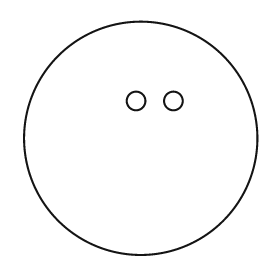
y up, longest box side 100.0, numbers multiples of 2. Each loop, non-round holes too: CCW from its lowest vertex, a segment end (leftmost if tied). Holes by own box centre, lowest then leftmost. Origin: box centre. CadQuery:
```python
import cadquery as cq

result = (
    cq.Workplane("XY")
    .moveTo(0.0, 0.0)
    .circle(50.0)
    .moveTo(-2.0, 16.0)
    .circle(4.0)
    .moveTo(14.0, 16.0)
    .circle(4.0)
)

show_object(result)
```